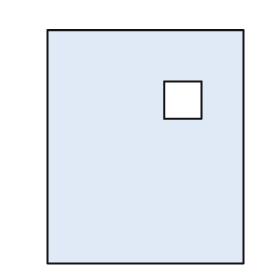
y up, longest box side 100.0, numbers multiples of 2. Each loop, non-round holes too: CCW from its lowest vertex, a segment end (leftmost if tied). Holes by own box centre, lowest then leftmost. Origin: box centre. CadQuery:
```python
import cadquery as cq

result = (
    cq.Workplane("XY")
    .moveTo(-42.0, -50.0)
    .lineTo(42.0, -50.0)
    .lineTo(42.0, 50.0)
    .lineTo(-42.0, 50.0)
    .close()
    .moveTo(8.0, 12.0)
    .lineTo(24.0, 12.0)
    .lineTo(24.0, 28.0)
    .lineTo(8.0, 28.0)
    .close()
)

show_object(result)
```